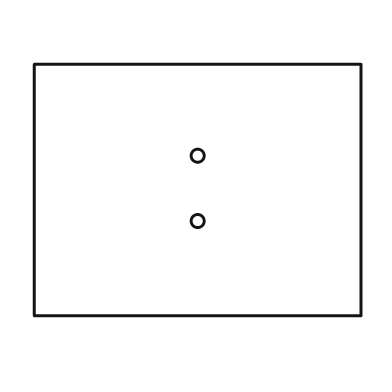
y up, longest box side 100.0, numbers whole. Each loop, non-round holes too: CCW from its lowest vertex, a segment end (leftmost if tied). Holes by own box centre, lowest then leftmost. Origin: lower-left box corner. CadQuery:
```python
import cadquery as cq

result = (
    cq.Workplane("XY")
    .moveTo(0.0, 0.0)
    .lineTo(100.0, 0.0)
    .lineTo(100.0, 77.0)
    .lineTo(0.0, 77.0)
    .close()
    .moveTo(50.0, 29.0)
    .circle(2.0)
    .moveTo(50.0, 49.0)
    .circle(2.0)
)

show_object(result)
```